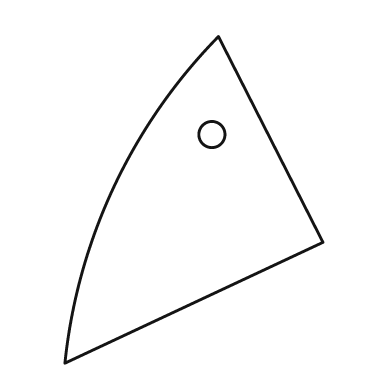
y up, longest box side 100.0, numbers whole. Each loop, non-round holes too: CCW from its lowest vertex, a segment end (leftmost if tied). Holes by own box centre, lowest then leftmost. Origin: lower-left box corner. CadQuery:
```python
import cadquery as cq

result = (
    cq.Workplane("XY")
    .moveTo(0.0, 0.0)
    .lineTo(79.0, 37.0)
    .lineTo(47.0, 100.0)
    .threePointArc((15.0, 54.0), (0.0, 0.0))
    .close()
    .moveTo(45.0, 70.0)
    .circle(4.0)
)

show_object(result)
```